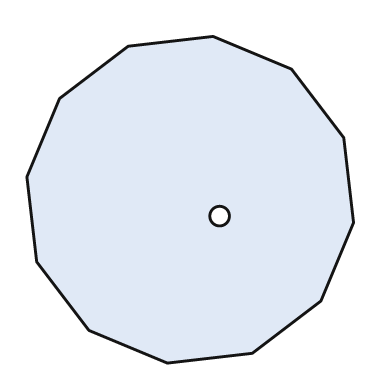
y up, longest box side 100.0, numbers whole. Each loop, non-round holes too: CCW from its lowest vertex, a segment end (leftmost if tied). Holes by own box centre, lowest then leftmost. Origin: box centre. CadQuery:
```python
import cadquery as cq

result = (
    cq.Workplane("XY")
    .moveTo(-7.0, -50.0)
    .lineTo(19.0, -47.0)
    .lineTo(40.0, -31.0)
    .lineTo(50.0, -7.0)
    .lineTo(47.0, 19.0)
    .lineTo(31.0, 40.0)
    .lineTo(7.0, 50.0)
    .lineTo(-19.0, 47.0)
    .lineTo(-40.0, 31.0)
    .lineTo(-50.0, 7.0)
    .lineTo(-47.0, -19.0)
    .lineTo(-31.0, -40.0)
    .close()
    .moveTo(9.0, -5.0)
    .circle(3.0)
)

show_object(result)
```